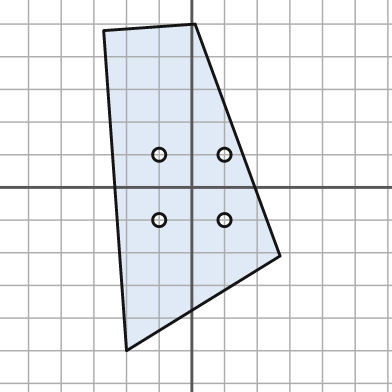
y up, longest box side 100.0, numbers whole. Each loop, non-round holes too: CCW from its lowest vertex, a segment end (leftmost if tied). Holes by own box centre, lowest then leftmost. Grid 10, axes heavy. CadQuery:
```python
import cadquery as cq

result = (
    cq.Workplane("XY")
    .moveTo(-20.0, -50.0)
    .lineTo(27.0, -21.0)
    .lineTo(1.0, 50.0)
    .lineTo(-27.0, 48.0)
    .close()
    .moveTo(-10.0, -10.0)
    .circle(2.0)
    .moveTo(10.0, -10.0)
    .circle(2.0)
    .moveTo(-10.0, 10.0)
    .circle(2.0)
    .moveTo(10.0, 10.0)
    .circle(2.0)
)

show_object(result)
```